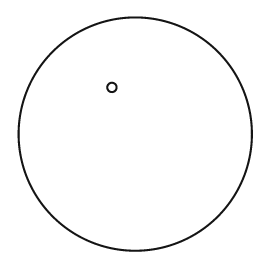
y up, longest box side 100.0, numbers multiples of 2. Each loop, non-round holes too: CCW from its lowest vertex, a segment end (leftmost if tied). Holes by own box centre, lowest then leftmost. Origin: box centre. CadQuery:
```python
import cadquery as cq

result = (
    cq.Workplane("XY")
    .moveTo(0.0, 0.0)
    .circle(50.0)
    .moveTo(-10.0, 20.0)
    .circle(2.0)
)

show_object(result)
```